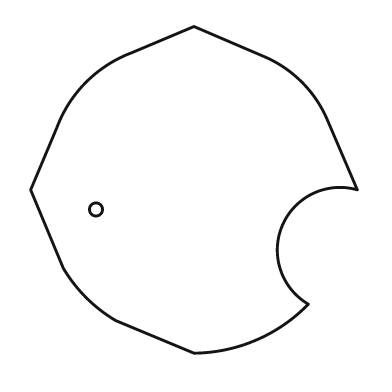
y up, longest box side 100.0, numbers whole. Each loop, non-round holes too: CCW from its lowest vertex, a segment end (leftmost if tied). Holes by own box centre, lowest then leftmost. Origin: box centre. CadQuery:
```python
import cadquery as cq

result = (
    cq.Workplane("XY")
    .moveTo(0.0, -50.0)
    .threePointArc((19.0, -46.0), (35.0, -35.0))
    .threePointArc((27.0, -11.0), (50.0, 0.0))
    .lineTo(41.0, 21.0)
    .threePointArc((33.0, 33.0), (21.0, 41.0))
    .lineTo(0.0, 50.0)
    .lineTo(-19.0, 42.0)
    .threePointArc((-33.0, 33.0), (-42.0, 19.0))
    .lineTo(-50.0, 0.0)
    .lineTo(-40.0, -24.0)
    .threePointArc((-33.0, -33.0), (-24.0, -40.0))
    .close()
    .moveTo(-30.0, -6.0)
    .circle(2.0)
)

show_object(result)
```